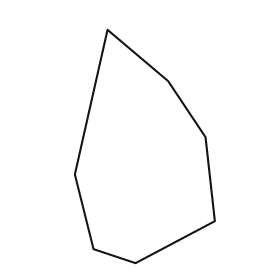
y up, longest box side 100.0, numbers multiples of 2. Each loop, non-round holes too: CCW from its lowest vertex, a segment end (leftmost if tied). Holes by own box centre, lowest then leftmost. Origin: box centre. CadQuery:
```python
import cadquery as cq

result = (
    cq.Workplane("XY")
    .moveTo(-4.0, -50.0)
    .lineTo(30.0, -32.0)
    .lineTo(26.0, 4.0)
    .lineTo(10.0, 28.0)
    .lineTo(-16.0, 50.0)
    .lineTo(-30.0, -12.0)
    .lineTo(-22.0, -44.0)
    .close()
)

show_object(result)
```